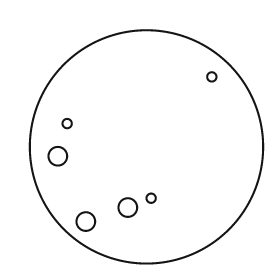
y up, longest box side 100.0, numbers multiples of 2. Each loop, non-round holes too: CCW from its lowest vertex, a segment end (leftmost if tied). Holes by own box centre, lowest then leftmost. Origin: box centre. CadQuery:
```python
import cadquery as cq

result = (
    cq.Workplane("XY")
    .moveTo(0.0, 0.0)
    .circle(50.0)
    .moveTo(-26.0, -32.0)
    .circle(4.0)
    .moveTo(-8.0, -26.0)
    .circle(4.0)
    .moveTo(2.0, -22.0)
    .circle(2.0)
    .moveTo(-38.0, -4.0)
    .circle(4.0)
    .moveTo(-34.0, 10.0)
    .circle(2.0)
    .moveTo(28.0, 30.0)
    .circle(2.0)
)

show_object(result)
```